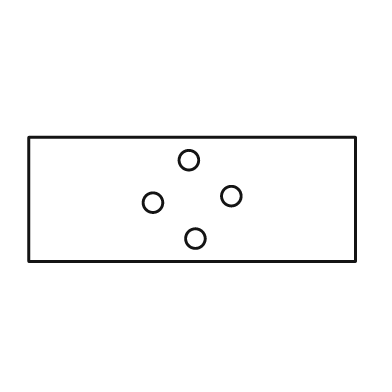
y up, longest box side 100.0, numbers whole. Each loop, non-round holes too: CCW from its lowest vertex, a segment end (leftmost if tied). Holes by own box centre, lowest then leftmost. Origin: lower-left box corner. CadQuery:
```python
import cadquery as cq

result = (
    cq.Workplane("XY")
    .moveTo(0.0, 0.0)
    .lineTo(100.0, 0.0)
    .lineTo(100.0, 38.0)
    .lineTo(0.0, 38.0)
    .close()
    .moveTo(51.0, 7.0)
    .circle(3.0)
    .moveTo(38.0, 18.0)
    .circle(3.0)
    .moveTo(62.0, 20.0)
    .circle(3.0)
    .moveTo(49.0, 31.0)
    .circle(3.0)
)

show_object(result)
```